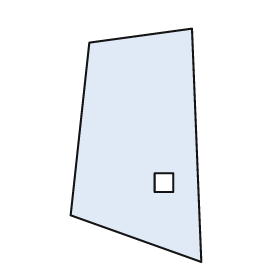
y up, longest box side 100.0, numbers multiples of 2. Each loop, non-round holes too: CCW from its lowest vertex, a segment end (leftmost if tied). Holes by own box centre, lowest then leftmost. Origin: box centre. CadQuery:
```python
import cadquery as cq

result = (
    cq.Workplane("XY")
    .moveTo(28.0, -50.0)
    .lineTo(24.0, 50.0)
    .lineTo(-20.0, 44.0)
    .lineTo(-28.0, -30.0)
    .close()
    .moveTo(8.0, -20.0)
    .lineTo(16.0, -20.0)
    .lineTo(16.0, -12.0)
    .lineTo(8.0, -12.0)
    .close()
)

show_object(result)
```